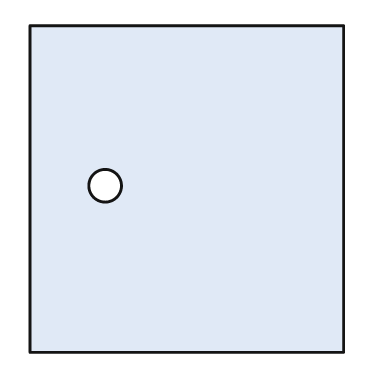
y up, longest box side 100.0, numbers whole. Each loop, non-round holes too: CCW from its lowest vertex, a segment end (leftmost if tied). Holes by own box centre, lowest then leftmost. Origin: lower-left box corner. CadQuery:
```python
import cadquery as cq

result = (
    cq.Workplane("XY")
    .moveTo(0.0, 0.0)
    .lineTo(96.0, 0.0)
    .lineTo(96.0, 100.0)
    .lineTo(0.0, 100.0)
    .close()
    .moveTo(23.0, 51.0)
    .circle(5.0)
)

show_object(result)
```